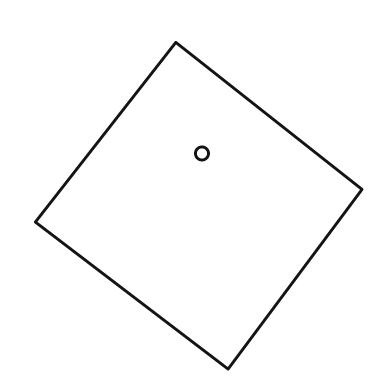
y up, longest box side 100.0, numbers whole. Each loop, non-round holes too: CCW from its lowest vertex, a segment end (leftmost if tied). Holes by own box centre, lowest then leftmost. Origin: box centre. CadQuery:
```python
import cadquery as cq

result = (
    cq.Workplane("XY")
    .moveTo(9.0, -50.0)
    .lineTo(50.0, 5.0)
    .lineTo(-7.0, 50.0)
    .lineTo(-50.0, -5.0)
    .close()
    .moveTo(1.0, 16.0)
    .circle(2.0)
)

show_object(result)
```